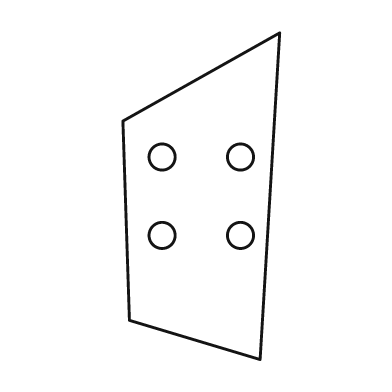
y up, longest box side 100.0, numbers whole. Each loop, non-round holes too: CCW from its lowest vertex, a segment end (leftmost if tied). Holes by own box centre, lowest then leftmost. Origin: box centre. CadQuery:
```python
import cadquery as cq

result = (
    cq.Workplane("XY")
    .moveTo(18.0, -50.0)
    .lineTo(24.0, 50.0)
    .lineTo(-24.0, 23.0)
    .lineTo(-22.0, -38.0)
    .close()
    .moveTo(-12.0, -12.0)
    .circle(4.0)
    .moveTo(12.0, -12.0)
    .circle(4.0)
    .moveTo(-12.0, 12.0)
    .circle(4.0)
    .moveTo(12.0, 12.0)
    .circle(4.0)
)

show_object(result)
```